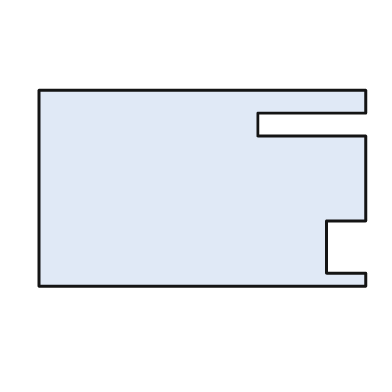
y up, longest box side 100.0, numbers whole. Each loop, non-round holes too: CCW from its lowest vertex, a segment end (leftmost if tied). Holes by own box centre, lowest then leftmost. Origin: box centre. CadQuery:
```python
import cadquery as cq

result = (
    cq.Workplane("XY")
    .moveTo(-50.0, -30.0)
    .lineTo(50.0, -30.0)
    .lineTo(50.0, -26.0)
    .lineTo(38.0, -26.0)
    .lineTo(38.0, -10.0)
    .lineTo(50.0, -10.0)
    .lineTo(50.0, 16.0)
    .lineTo(17.0, 16.0)
    .lineTo(17.0, 23.0)
    .lineTo(50.0, 23.0)
    .lineTo(50.0, 30.0)
    .lineTo(-50.0, 30.0)
    .close()
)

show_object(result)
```